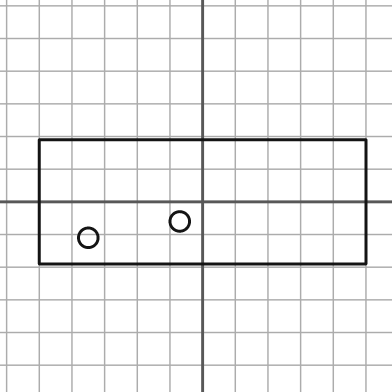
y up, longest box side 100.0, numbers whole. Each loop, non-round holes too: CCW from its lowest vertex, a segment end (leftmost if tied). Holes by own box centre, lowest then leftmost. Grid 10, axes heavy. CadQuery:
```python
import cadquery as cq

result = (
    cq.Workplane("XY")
    .moveTo(-50.0, -19.0)
    .lineTo(50.0, -19.0)
    .lineTo(50.0, 19.0)
    .lineTo(-50.0, 19.0)
    .close()
    .moveTo(-35.0, -11.0)
    .circle(3.0)
    .moveTo(-7.0, -6.0)
    .circle(3.0)
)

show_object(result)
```